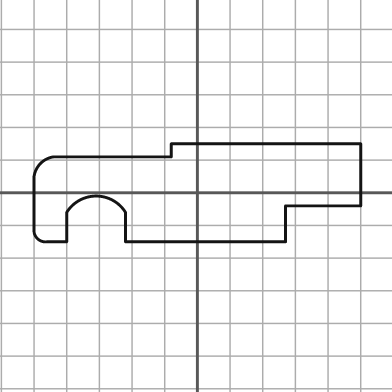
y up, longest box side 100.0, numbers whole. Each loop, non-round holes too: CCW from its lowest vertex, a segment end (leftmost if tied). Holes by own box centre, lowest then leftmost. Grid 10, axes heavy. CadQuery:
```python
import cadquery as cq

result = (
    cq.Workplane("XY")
    .moveTo(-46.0, -15.0)
    .lineTo(-40.0, -15.0)
    .lineTo(-40.0, -6.0)
    .threePointArc((-31.0, -1.0), (-22.0, -6.0))
    .lineTo(-22.0, -15.0)
    .lineTo(27.0, -15.0)
    .lineTo(27.0, -4.0)
    .lineTo(50.0, -4.0)
    .lineTo(50.0, 15.0)
    .lineTo(-8.0, 15.0)
    .lineTo(-8.0, 11.0)
    .lineTo(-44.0, 11.0)
    .threePointArc((-48.0, 9.0), (-50.0, 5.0))
    .lineTo(-50.0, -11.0)
    .threePointArc((-49.0, -14.0), (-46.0, -15.0))
    .close()
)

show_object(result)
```